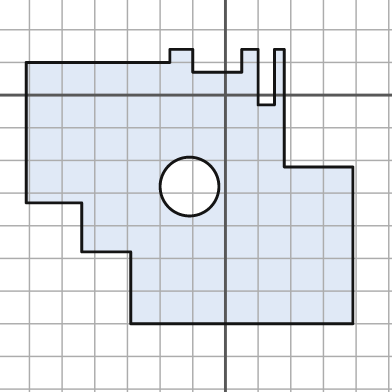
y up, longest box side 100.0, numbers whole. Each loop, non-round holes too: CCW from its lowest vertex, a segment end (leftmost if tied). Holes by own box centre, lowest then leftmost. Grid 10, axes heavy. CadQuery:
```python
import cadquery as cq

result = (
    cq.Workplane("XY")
    .moveTo(-29.0, -70.0)
    .lineTo(39.0, -70.0)
    .lineTo(39.0, -22.0)
    .lineTo(18.0, -22.0)
    .lineTo(18.0, 14.0)
    .lineTo(15.0, 14.0)
    .lineTo(15.0, -3.0)
    .lineTo(10.0, -3.0)
    .lineTo(10.0, 14.0)
    .lineTo(5.0, 14.0)
    .lineTo(5.0, 7.0)
    .lineTo(-10.0, 7.0)
    .lineTo(-10.0, 14.0)
    .lineTo(-17.0, 14.0)
    .lineTo(-17.0, 10.0)
    .lineTo(-61.0, 10.0)
    .lineTo(-61.0, -33.0)
    .lineTo(-44.0, -33.0)
    .lineTo(-44.0, -48.0)
    .lineTo(-29.0, -48.0)
    .close()
    .moveTo(-11.0, -28.0)
    .circle(9.0)
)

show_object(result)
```